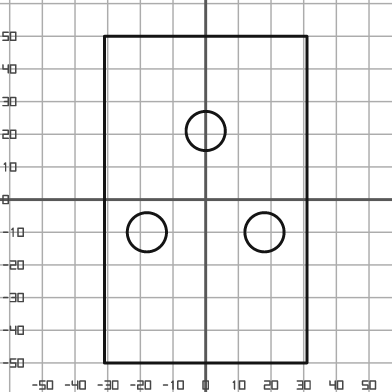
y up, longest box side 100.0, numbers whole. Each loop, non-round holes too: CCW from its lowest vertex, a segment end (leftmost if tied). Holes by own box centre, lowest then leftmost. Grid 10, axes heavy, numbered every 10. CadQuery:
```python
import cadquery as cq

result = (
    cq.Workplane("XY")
    .moveTo(-31.0, -50.0)
    .lineTo(31.0, -50.0)
    .lineTo(31.0, 50.0)
    .lineTo(-31.0, 50.0)
    .close()
    .moveTo(-18.0, -10.0)
    .circle(6.0)
    .moveTo(18.0, -10.0)
    .circle(6.0)
    .moveTo(0.0, 21.0)
    .circle(6.0)
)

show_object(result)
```